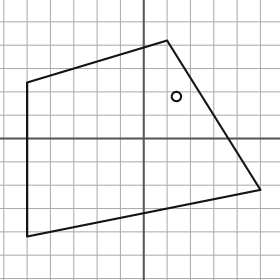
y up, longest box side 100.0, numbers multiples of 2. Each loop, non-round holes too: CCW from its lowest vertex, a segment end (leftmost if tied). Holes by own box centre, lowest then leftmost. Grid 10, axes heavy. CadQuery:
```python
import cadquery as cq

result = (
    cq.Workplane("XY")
    .moveTo(-50.0, -42.0)
    .lineTo(50.0, -22.0)
    .lineTo(10.0, 42.0)
    .lineTo(-50.0, 24.0)
    .close()
    .moveTo(14.0, 18.0)
    .circle(2.0)
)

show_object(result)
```